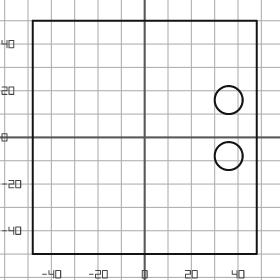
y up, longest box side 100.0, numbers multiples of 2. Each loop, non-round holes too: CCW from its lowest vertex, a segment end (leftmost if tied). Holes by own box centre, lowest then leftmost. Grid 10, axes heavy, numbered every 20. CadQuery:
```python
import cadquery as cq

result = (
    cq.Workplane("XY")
    .moveTo(-48.0, -50.0)
    .lineTo(48.0, -50.0)
    .lineTo(48.0, 50.0)
    .lineTo(-48.0, 50.0)
    .close()
    .moveTo(36.0, -8.0)
    .circle(6.0)
    .moveTo(36.0, 16.0)
    .circle(6.0)
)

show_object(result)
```